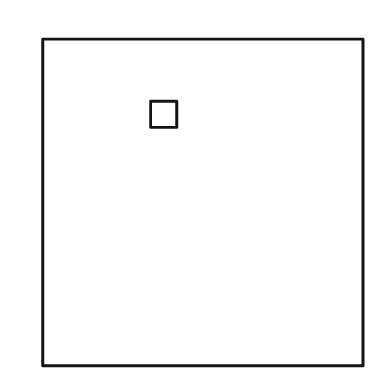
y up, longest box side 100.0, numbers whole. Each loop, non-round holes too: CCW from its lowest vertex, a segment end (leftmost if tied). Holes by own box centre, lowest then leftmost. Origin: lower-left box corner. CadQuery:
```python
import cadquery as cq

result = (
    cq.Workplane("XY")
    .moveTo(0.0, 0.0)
    .lineTo(98.0, 0.0)
    .lineTo(98.0, 100.0)
    .lineTo(0.0, 100.0)
    .close()
    .moveTo(33.0, 73.0)
    .lineTo(41.0, 73.0)
    .lineTo(41.0, 81.0)
    .lineTo(33.0, 81.0)
    .close()
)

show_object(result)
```